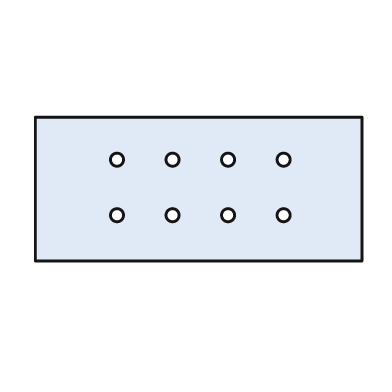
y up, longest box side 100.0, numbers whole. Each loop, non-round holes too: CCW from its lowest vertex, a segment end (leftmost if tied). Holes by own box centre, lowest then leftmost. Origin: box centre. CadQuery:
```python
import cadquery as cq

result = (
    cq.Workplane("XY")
    .moveTo(-50.0, -22.0)
    .lineTo(50.0, -22.0)
    .lineTo(50.0, 22.0)
    .lineTo(-50.0, 22.0)
    .close()
    .moveTo(-25.0, -8.0)
    .circle(2.0)
    .moveTo(-8.0, -8.0)
    .circle(2.0)
    .moveTo(9.0, -8.0)
    .circle(2.0)
    .moveTo(26.0, -8.0)
    .circle(2.0)
    .moveTo(-25.0, 9.0)
    .circle(2.0)
    .moveTo(-8.0, 9.0)
    .circle(2.0)
    .moveTo(9.0, 9.0)
    .circle(2.0)
    .moveTo(26.0, 9.0)
    .circle(2.0)
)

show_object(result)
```